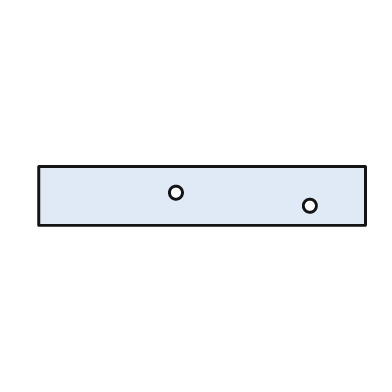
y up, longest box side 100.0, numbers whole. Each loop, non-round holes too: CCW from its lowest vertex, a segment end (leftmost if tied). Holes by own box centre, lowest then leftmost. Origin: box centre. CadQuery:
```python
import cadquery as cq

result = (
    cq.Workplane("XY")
    .moveTo(-50.0, -9.0)
    .lineTo(50.0, -9.0)
    .lineTo(50.0, 9.0)
    .lineTo(-50.0, 9.0)
    .close()
    .moveTo(33.0, -3.0)
    .circle(2.0)
    .moveTo(-8.0, 1.0)
    .circle(2.0)
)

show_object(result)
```